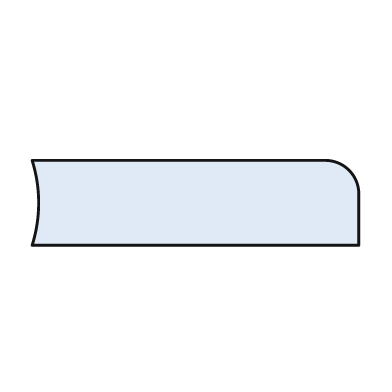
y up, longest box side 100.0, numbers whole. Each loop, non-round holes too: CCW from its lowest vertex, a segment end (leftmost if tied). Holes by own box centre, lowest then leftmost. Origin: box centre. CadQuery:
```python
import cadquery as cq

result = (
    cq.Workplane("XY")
    .moveTo(-50.0, -13.0)
    .lineTo(50.0, -13.0)
    .lineTo(50.0, 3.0)
    .threePointArc((47.0, 10.0), (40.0, 13.0))
    .lineTo(-50.0, 13.0)
    .threePointArc((-48.0, 0.0), (-50.0, -13.0))
    .close()
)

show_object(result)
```